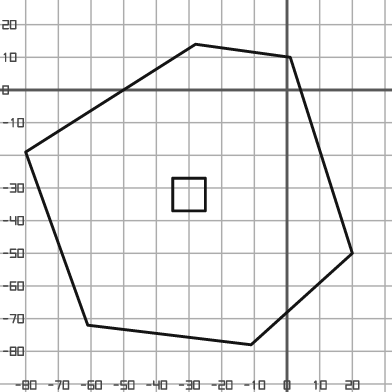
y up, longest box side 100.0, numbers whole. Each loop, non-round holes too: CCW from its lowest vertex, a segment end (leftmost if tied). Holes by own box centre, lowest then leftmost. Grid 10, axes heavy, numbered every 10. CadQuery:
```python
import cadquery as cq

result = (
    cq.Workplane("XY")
    .moveTo(-11.0, -78.0)
    .lineTo(20.0, -50.0)
    .lineTo(1.0, 10.0)
    .lineTo(-28.0, 14.0)
    .lineTo(-80.0, -19.0)
    .lineTo(-61.0, -72.0)
    .close()
    .moveTo(-35.0, -37.0)
    .lineTo(-25.0, -37.0)
    .lineTo(-25.0, -27.0)
    .lineTo(-35.0, -27.0)
    .close()
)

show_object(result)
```